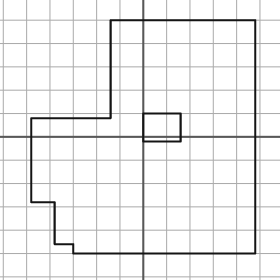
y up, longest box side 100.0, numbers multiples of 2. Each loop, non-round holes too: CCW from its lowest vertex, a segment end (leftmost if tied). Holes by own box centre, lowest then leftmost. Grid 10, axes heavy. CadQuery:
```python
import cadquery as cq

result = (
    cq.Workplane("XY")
    .moveTo(-30.0, -50.0)
    .lineTo(48.0, -50.0)
    .lineTo(48.0, 50.0)
    .lineTo(-14.0, 50.0)
    .lineTo(-14.0, 8.0)
    .lineTo(-48.0, 8.0)
    .lineTo(-48.0, -28.0)
    .lineTo(-38.0, -28.0)
    .lineTo(-38.0, -46.0)
    .lineTo(-30.0, -46.0)
    .close()
    .moveTo(0.0, -2.0)
    .lineTo(16.0, -2.0)
    .lineTo(16.0, 10.0)
    .lineTo(0.0, 10.0)
    .close()
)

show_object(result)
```